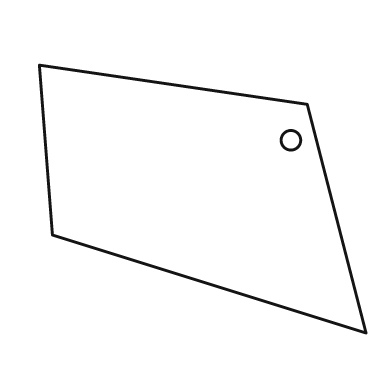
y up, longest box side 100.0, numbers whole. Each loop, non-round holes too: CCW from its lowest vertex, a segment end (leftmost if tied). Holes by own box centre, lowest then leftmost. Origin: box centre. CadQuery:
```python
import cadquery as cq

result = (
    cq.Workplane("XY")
    .moveTo(50.0, -41.0)
    .lineTo(32.0, 29.0)
    .lineTo(-50.0, 41.0)
    .lineTo(-46.0, -11.0)
    .close()
    .moveTo(27.0, 18.0)
    .circle(3.0)
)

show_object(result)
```